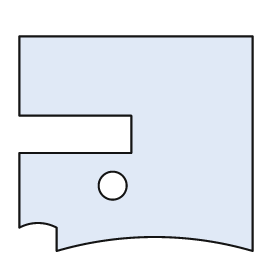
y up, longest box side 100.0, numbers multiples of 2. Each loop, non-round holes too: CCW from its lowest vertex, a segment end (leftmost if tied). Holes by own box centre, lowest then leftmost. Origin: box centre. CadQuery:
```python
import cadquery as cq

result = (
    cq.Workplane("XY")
    .moveTo(-34.0, -46.0)
    .threePointArc((8.0, -40.0), (50.0, -46.0))
    .lineTo(50.0, 46.0)
    .lineTo(-50.0, 46.0)
    .lineTo(-50.0, 12.0)
    .lineTo(-2.0, 12.0)
    .lineTo(-2.0, -4.0)
    .lineTo(-50.0, -4.0)
    .lineTo(-50.0, -36.0)
    .threePointArc((-42.0, -34.0), (-34.0, -36.0))
    .close()
    .moveTo(-10.0, -18.0)
    .circle(6.0)
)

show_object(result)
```